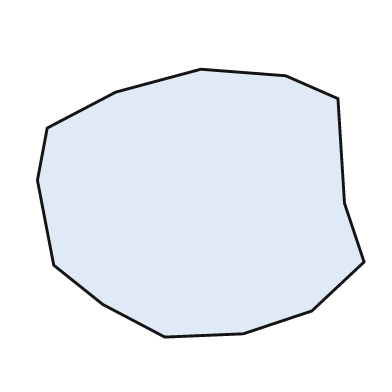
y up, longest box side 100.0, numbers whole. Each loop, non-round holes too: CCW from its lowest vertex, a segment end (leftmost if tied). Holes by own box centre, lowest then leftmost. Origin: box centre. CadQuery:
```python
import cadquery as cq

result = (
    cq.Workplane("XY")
    .moveTo(-11.0, -41.0)
    .lineTo(13.0, -40.0)
    .lineTo(34.0, -33.0)
    .lineTo(50.0, -18.0)
    .lineTo(44.0, 0.0)
    .lineTo(42.0, 32.0)
    .lineTo(26.0, 39.0)
    .lineTo(0.0, 41.0)
    .lineTo(-26.0, 34.0)
    .lineTo(-47.0, 23.0)
    .lineTo(-50.0, 7.0)
    .lineTo(-45.0, -19.0)
    .lineTo(-30.0, -31.0)
    .close()
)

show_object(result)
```